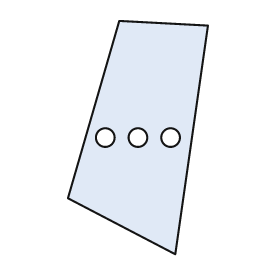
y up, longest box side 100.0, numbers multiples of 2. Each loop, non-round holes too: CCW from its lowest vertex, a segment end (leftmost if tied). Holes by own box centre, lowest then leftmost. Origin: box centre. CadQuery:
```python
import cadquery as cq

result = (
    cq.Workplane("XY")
    .moveTo(16.0, -50.0)
    .lineTo(30.0, 48.0)
    .lineTo(-8.0, 50.0)
    .lineTo(-30.0, -26.0)
    .close()
    .moveTo(-14.0, 0.0)
    .circle(4.0)
    .moveTo(0.0, 0.0)
    .circle(4.0)
    .moveTo(14.0, 0.0)
    .circle(4.0)
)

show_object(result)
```